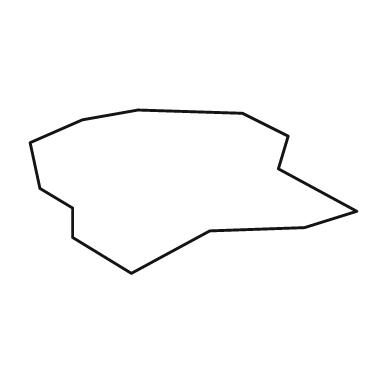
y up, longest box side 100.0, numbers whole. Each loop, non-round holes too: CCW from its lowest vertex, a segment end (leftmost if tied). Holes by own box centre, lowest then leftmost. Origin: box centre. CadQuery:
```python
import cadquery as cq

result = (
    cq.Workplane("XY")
    .moveTo(-19.0, -25.0)
    .lineTo(5.0, -12.0)
    .lineTo(34.0, -11.0)
    .lineTo(50.0, -6.0)
    .lineTo(26.0, 7.0)
    .lineTo(29.0, 17.0)
    .lineTo(15.0, 24.0)
    .lineTo(-17.0, 25.0)
    .lineTo(-34.0, 22.0)
    .lineTo(-50.0, 15.0)
    .lineTo(-47.0, 1.0)
    .lineTo(-37.0, -5.0)
    .lineTo(-37.0, -14.0)
    .close()
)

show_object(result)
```